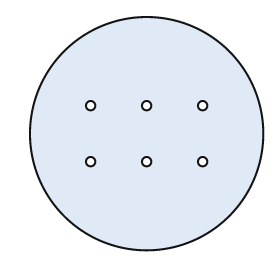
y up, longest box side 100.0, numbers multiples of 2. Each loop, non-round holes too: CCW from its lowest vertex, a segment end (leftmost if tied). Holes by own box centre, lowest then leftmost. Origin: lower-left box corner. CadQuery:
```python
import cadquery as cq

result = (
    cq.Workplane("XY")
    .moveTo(50.0, 50.0)
    .circle(50.0)
    .moveTo(26.0, 38.0)
    .circle(2.0)
    .moveTo(50.0, 38.0)
    .circle(2.0)
    .moveTo(74.0, 38.0)
    .circle(2.0)
    .moveTo(26.0, 62.0)
    .circle(2.0)
    .moveTo(50.0, 62.0)
    .circle(2.0)
    .moveTo(74.0, 62.0)
    .circle(2.0)
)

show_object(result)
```